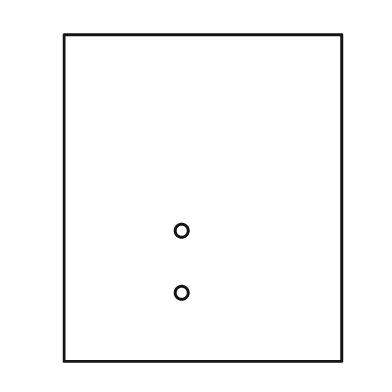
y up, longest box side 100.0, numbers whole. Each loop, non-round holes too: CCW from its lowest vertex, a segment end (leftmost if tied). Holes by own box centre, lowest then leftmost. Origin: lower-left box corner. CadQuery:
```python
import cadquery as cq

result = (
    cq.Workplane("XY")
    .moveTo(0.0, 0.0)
    .lineTo(85.0, 0.0)
    .lineTo(85.0, 100.0)
    .lineTo(0.0, 100.0)
    .close()
    .moveTo(36.0, 21.0)
    .circle(2.0)
    .moveTo(36.0, 40.0)
    .circle(2.0)
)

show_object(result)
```